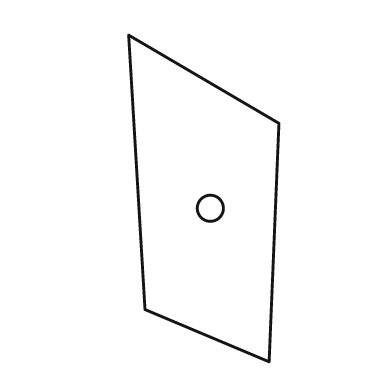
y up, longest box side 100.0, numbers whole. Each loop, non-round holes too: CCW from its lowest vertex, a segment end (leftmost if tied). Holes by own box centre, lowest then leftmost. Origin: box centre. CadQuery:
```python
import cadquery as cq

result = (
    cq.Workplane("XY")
    .moveTo(20.0, -50.0)
    .lineTo(23.0, 23.0)
    .lineTo(-23.0, 50.0)
    .lineTo(-18.0, -34.0)
    .close()
    .moveTo(2.0, -3.0)
    .circle(4.0)
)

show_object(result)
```